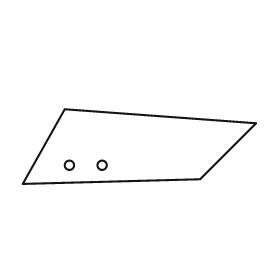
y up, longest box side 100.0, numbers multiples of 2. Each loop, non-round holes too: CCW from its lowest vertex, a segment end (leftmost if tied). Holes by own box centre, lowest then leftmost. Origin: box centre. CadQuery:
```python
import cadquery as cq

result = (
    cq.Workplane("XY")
    .moveTo(-50.0, -16.0)
    .lineTo(26.0, -14.0)
    .lineTo(50.0, 10.0)
    .lineTo(-32.0, 16.0)
    .close()
    .moveTo(-30.0, -8.0)
    .circle(2.0)
    .moveTo(-16.0, -8.0)
    .circle(2.0)
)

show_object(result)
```